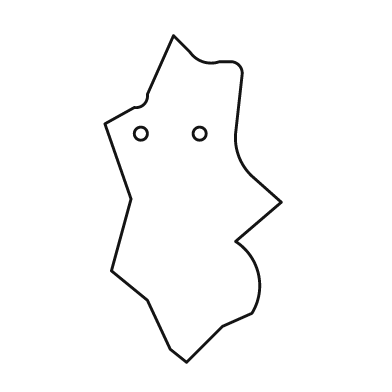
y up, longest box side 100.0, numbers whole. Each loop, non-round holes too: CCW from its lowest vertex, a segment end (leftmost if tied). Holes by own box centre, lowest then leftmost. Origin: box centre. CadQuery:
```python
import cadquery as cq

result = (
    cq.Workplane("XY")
    .moveTo(-2.0, -50.0)
    .lineTo(9.0, -39.0)
    .lineTo(18.0, -35.0)
    .threePointArc((20.0, -23.0), (13.0, -13.0))
    .lineTo(27.0, -1.0)
    .lineTo(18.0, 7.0)
    .threePointArc((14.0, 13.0), (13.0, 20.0))
    .lineTo(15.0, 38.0)
    .threePointArc((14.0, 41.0), (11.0, 42.0))
    .lineTo(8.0, 42.0)
    .threePointArc((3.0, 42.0), (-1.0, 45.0))
    .lineTo(-6.0, 50.0)
    .lineTo(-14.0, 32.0)
    .threePointArc((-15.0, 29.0), (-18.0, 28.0))
    .lineTo(-27.0, 23.0)
    .lineTo(-19.0, 0.0)
    .lineTo(-25.0, -22.0)
    .lineTo(-14.0, -31.0)
    .lineTo(-7.0, -46.0)
    .close()
    .moveTo(-16.0, 20.0)
    .circle(2.0)
    .moveTo(2.0, 20.0)
    .circle(2.0)
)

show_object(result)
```